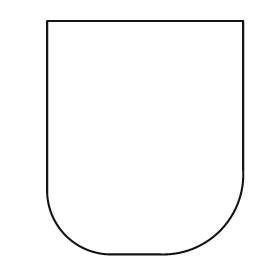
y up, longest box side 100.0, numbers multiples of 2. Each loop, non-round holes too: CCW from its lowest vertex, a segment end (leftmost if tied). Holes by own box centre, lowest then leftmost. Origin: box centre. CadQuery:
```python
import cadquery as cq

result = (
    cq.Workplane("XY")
    .moveTo(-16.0, -50.0)
    .lineTo(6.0, -50.0)
    .threePointArc((32.0, -40.0), (42.0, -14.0))
    .lineTo(42.0, 50.0)
    .lineTo(-42.0, 50.0)
    .lineTo(-42.0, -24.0)
    .threePointArc((-34.0, -42.0), (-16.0, -50.0))
    .close()
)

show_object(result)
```